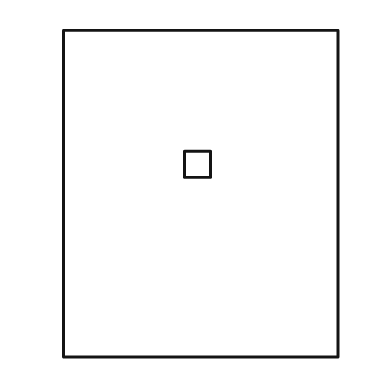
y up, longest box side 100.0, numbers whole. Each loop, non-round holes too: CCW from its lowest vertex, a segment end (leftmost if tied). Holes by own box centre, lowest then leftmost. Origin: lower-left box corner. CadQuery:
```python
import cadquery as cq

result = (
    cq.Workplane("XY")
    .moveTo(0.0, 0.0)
    .lineTo(84.0, 0.0)
    .lineTo(84.0, 100.0)
    .lineTo(0.0, 100.0)
    .close()
    .moveTo(37.0, 55.0)
    .lineTo(45.0, 55.0)
    .lineTo(45.0, 63.0)
    .lineTo(37.0, 63.0)
    .close()
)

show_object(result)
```